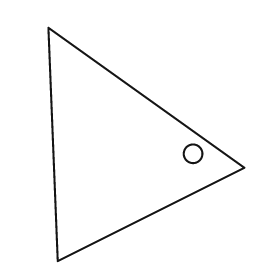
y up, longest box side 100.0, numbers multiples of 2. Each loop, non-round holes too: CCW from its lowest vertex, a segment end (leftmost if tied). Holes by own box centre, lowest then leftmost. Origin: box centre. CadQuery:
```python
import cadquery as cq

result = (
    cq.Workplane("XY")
    .moveTo(-38.0, -50.0)
    .lineTo(42.0, -10.0)
    .lineTo(-42.0, 50.0)
    .close()
    .moveTo(20.0, -4.0)
    .circle(4.0)
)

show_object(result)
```